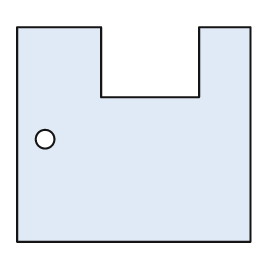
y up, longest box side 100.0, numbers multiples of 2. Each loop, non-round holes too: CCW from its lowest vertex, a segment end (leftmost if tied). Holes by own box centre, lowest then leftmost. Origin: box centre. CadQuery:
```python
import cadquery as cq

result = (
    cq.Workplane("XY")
    .moveTo(-50.0, -46.0)
    .lineTo(50.0, -46.0)
    .lineTo(50.0, 46.0)
    .lineTo(28.0, 46.0)
    .lineTo(28.0, 16.0)
    .lineTo(-14.0, 16.0)
    .lineTo(-14.0, 46.0)
    .lineTo(-50.0, 46.0)
    .close()
    .moveTo(-38.0, -2.0)
    .circle(4.0)
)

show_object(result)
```